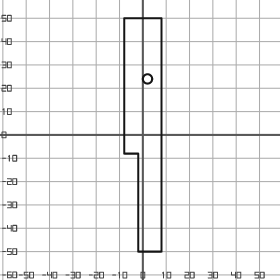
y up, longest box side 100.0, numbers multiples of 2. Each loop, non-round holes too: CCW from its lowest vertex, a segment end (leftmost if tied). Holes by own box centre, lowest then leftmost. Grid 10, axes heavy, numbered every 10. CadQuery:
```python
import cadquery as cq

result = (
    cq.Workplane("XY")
    .moveTo(-2.0, -50.0)
    .lineTo(8.0, -50.0)
    .lineTo(8.0, 50.0)
    .lineTo(-8.0, 50.0)
    .lineTo(-8.0, -8.0)
    .lineTo(-2.0, -8.0)
    .close()
    .moveTo(2.0, 24.0)
    .circle(2.0)
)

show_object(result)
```